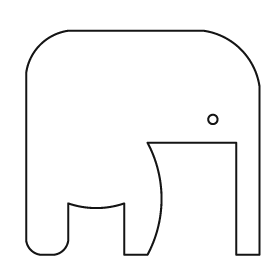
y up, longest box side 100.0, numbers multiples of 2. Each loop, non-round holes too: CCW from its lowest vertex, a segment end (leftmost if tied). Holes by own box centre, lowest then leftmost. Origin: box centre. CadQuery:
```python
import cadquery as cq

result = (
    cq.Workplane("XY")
    .moveTo(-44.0, -48.0)
    .lineTo(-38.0, -48.0)
    .threePointArc((-34.0, -46.0), (-32.0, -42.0))
    .lineTo(-32.0, -26.0)
    .threePointArc((-20.0, -28.0), (-8.0, -26.0))
    .lineTo(-8.0, -48.0)
    .lineTo(2.0, -48.0)
    .threePointArc((8.0, -24.0), (2.0, 0.0))
    .lineTo(40.0, 0.0)
    .lineTo(40.0, -48.0)
    .lineTo(50.0, -48.0)
    .lineTo(50.0, 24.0)
    .threePointArc((42.0, 40.0), (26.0, 48.0))
    .lineTo(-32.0, 48.0)
    .threePointArc((-44.0, 42.0), (-50.0, 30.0))
    .lineTo(-50.0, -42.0)
    .threePointArc((-48.0, -46.0), (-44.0, -48.0))
    .close()
    .moveTo(30.0, 10.0)
    .circle(2.0)
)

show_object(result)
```